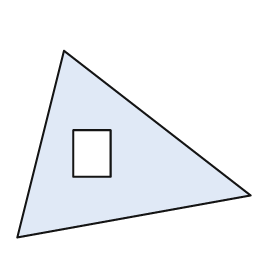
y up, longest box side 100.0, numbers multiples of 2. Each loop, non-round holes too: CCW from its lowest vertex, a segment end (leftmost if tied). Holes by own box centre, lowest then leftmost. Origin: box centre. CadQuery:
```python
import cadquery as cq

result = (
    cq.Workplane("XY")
    .moveTo(-50.0, -40.0)
    .lineTo(50.0, -22.0)
    .lineTo(-30.0, 40.0)
    .close()
    .moveTo(-26.0, -14.0)
    .lineTo(-10.0, -14.0)
    .lineTo(-10.0, 6.0)
    .lineTo(-26.0, 6.0)
    .close()
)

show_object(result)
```